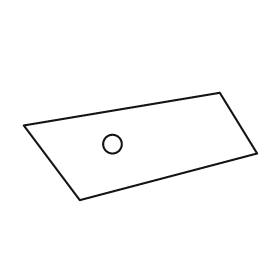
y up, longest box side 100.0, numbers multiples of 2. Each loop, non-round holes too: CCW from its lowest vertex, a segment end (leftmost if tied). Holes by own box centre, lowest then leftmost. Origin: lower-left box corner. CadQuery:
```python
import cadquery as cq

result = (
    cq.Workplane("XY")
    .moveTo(24.0, 0.0)
    .lineTo(100.0, 20.0)
    .lineTo(84.0, 46.0)
    .lineTo(0.0, 32.0)
    .close()
    .moveTo(38.0, 24.0)
    .circle(4.0)
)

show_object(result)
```